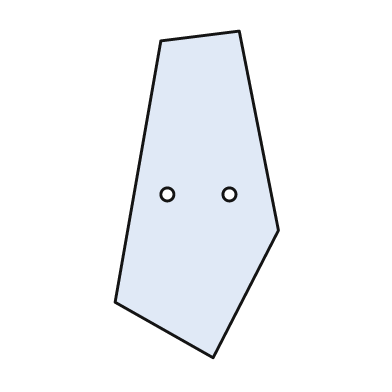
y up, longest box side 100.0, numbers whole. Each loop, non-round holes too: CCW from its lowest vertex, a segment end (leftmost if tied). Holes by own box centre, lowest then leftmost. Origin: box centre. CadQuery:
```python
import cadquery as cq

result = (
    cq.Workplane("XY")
    .moveTo(5.0, -50.0)
    .lineTo(25.0, -11.0)
    .lineTo(13.0, 50.0)
    .lineTo(-11.0, 47.0)
    .lineTo(-25.0, -33.0)
    .close()
    .moveTo(-9.0, 0.0)
    .circle(2.0)
    .moveTo(10.0, 0.0)
    .circle(2.0)
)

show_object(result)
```